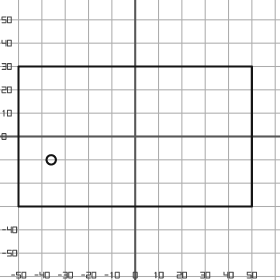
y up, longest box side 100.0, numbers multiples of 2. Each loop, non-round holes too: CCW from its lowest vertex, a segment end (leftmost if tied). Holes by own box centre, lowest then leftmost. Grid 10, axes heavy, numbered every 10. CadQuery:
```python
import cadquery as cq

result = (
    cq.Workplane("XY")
    .moveTo(-50.0, -30.0)
    .lineTo(50.0, -30.0)
    .lineTo(50.0, 30.0)
    .lineTo(-50.0, 30.0)
    .close()
    .moveTo(-36.0, -10.0)
    .circle(2.0)
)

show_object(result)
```